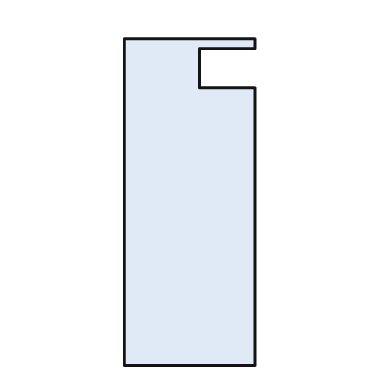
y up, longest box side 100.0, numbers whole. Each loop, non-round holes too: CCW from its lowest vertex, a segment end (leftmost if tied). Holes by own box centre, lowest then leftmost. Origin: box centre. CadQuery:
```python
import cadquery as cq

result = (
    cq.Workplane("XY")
    .moveTo(-20.0, -50.0)
    .lineTo(20.0, -50.0)
    .lineTo(20.0, 35.0)
    .lineTo(3.0, 35.0)
    .lineTo(3.0, 47.0)
    .lineTo(20.0, 47.0)
    .lineTo(20.0, 50.0)
    .lineTo(-20.0, 50.0)
    .close()
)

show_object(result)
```